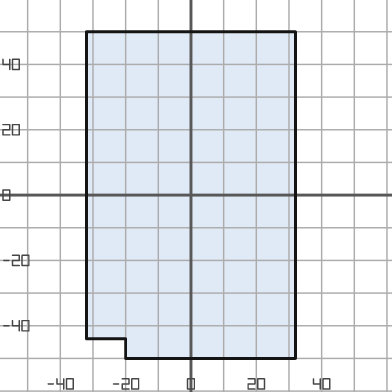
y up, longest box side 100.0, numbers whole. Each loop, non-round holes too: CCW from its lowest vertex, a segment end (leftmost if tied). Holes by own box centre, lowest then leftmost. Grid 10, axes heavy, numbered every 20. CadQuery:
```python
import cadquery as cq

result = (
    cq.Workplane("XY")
    .moveTo(-20.0, -50.0)
    .lineTo(32.0, -50.0)
    .lineTo(32.0, 50.0)
    .lineTo(-32.0, 50.0)
    .lineTo(-32.0, -44.0)
    .lineTo(-20.0, -44.0)
    .close()
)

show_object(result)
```